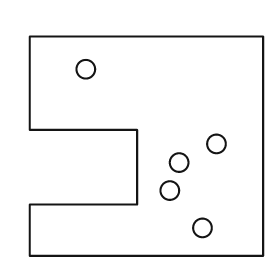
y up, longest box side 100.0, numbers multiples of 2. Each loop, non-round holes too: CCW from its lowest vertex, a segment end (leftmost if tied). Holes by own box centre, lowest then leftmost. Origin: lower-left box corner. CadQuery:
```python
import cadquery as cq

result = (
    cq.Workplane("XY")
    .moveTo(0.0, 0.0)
    .lineTo(100.0, 0.0)
    .lineTo(100.0, 94.0)
    .lineTo(0.0, 94.0)
    .lineTo(0.0, 54.0)
    .lineTo(46.0, 54.0)
    .lineTo(46.0, 22.0)
    .lineTo(0.0, 22.0)
    .close()
    .moveTo(74.0, 12.0)
    .circle(4.0)
    .moveTo(60.0, 28.0)
    .circle(4.0)
    .moveTo(64.0, 40.0)
    .circle(4.0)
    .moveTo(80.0, 48.0)
    .circle(4.0)
    .moveTo(24.0, 80.0)
    .circle(4.0)
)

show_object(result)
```